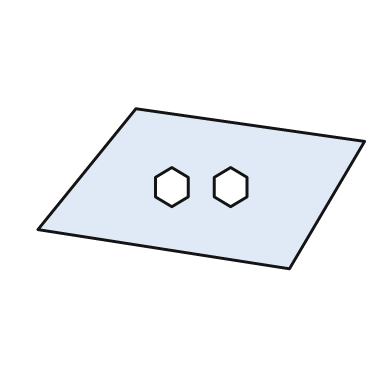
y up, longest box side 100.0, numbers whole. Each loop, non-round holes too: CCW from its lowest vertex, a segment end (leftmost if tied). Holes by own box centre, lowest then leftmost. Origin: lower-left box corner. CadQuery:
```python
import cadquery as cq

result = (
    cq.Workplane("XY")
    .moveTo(77.0, 0.0)
    .lineTo(100.0, 39.0)
    .lineTo(30.0, 49.0)
    .lineTo(0.0, 12.0)
    .close()
    .moveTo(41.0, 19.0)
    .lineTo(46.0, 22.0)
    .lineTo(46.0, 28.0)
    .lineTo(41.0, 31.0)
    .lineTo(36.0, 28.0)
    .lineTo(36.0, 22.0)
    .close()
    .moveTo(59.0, 19.0)
    .lineTo(64.0, 22.0)
    .lineTo(64.0, 28.0)
    .lineTo(59.0, 31.0)
    .lineTo(54.0, 28.0)
    .lineTo(54.0, 22.0)
    .close()
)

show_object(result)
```